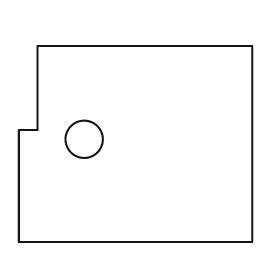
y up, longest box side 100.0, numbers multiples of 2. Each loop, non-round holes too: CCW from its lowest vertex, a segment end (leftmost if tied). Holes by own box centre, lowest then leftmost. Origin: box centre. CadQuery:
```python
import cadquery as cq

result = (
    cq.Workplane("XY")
    .moveTo(-50.0, -42.0)
    .lineTo(50.0, -42.0)
    .lineTo(50.0, 42.0)
    .lineTo(-42.0, 42.0)
    .lineTo(-42.0, 6.0)
    .lineTo(-50.0, 6.0)
    .close()
    .moveTo(-22.0, 2.0)
    .circle(8.0)
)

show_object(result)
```